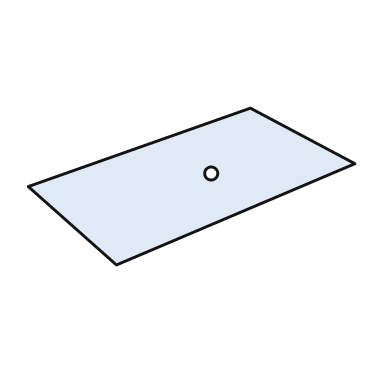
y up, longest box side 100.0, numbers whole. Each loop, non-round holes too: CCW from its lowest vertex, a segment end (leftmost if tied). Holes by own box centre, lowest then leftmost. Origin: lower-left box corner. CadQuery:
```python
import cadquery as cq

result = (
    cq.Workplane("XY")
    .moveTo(27.0, 0.0)
    .lineTo(100.0, 31.0)
    .lineTo(68.0, 48.0)
    .lineTo(0.0, 24.0)
    .close()
    .moveTo(56.0, 28.0)
    .circle(2.0)
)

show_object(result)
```